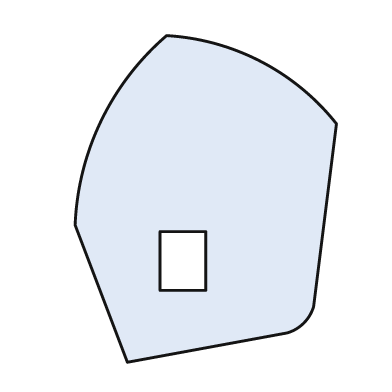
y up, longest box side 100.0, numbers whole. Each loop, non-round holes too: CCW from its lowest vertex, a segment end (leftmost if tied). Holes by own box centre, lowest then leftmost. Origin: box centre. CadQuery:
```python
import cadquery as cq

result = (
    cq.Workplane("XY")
    .moveTo(-24.0, -50.0)
    .lineTo(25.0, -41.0)
    .threePointArc((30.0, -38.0), (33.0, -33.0))
    .lineTo(40.0, 23.0)
    .threePointArc((17.0, 42.0), (-12.0, 50.0))
    .threePointArc((-32.0, 24.0), (-40.0, -8.0))
    .close()
    .moveTo(-14.0, -28.0)
    .lineTo(0.0, -28.0)
    .lineTo(0.0, -10.0)
    .lineTo(-14.0, -10.0)
    .close()
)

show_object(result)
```